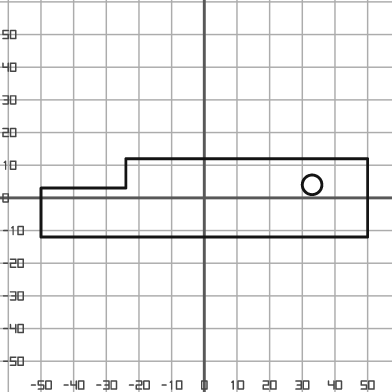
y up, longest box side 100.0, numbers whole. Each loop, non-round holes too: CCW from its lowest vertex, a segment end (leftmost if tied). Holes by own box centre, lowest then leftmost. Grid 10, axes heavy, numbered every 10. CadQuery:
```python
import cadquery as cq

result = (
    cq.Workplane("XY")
    .moveTo(-50.0, -12.0)
    .lineTo(50.0, -12.0)
    .lineTo(50.0, 12.0)
    .lineTo(-24.0, 12.0)
    .lineTo(-24.0, 3.0)
    .lineTo(-50.0, 3.0)
    .close()
    .moveTo(33.0, 4.0)
    .circle(3.0)
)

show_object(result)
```